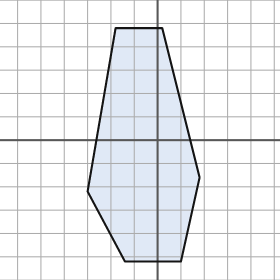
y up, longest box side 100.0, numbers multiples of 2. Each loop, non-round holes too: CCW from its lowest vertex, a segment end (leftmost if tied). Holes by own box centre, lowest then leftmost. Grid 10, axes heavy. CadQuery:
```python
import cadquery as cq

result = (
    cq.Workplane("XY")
    .moveTo(-14.0, -52.0)
    .lineTo(10.0, -52.0)
    .lineTo(18.0, -16.0)
    .lineTo(2.0, 48.0)
    .lineTo(-18.0, 48.0)
    .lineTo(-30.0, -22.0)
    .close()
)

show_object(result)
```